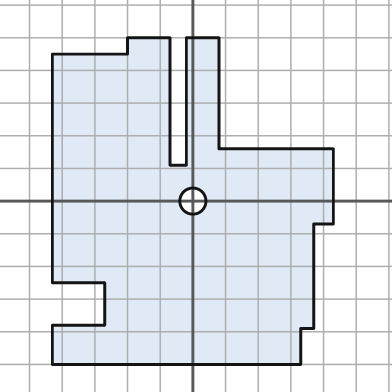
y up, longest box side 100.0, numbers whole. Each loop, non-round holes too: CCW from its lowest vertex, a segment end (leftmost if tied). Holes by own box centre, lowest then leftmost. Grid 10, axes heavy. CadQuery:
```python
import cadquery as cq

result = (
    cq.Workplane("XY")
    .moveTo(-43.0, -50.0)
    .lineTo(33.0, -50.0)
    .lineTo(33.0, -39.0)
    .lineTo(37.0, -39.0)
    .lineTo(37.0, -7.0)
    .lineTo(43.0, -7.0)
    .lineTo(43.0, 16.0)
    .lineTo(8.0, 16.0)
    .lineTo(8.0, 50.0)
    .lineTo(-2.0, 50.0)
    .lineTo(-2.0, 11.0)
    .lineTo(-7.0, 11.0)
    .lineTo(-7.0, 50.0)
    .lineTo(-20.0, 50.0)
    .lineTo(-20.0, 45.0)
    .lineTo(-43.0, 45.0)
    .lineTo(-43.0, -25.0)
    .lineTo(-27.0, -25.0)
    .lineTo(-27.0, -38.0)
    .lineTo(-43.0, -38.0)
    .close()
    .moveTo(0.0, 0.0)
    .circle(4.0)
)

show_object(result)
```